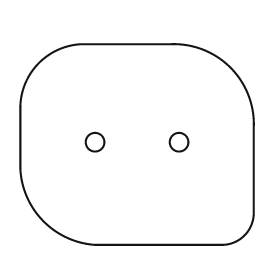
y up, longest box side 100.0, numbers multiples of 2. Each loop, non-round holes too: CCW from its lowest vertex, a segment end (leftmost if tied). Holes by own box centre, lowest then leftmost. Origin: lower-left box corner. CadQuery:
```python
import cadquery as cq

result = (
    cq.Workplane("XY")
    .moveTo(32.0, 0.0)
    .lineTo(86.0, 0.0)
    .threePointArc((96.0, 4.0), (100.0, 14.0))
    .lineTo(100.0, 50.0)
    .threePointArc((90.0, 76.0), (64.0, 86.0))
    .lineTo(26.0, 86.0)
    .threePointArc((8.0, 78.0), (0.0, 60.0))
    .lineTo(0.0, 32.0)
    .threePointArc((10.0, 10.0), (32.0, 0.0))
    .close()
    .moveTo(32.0, 44.0)
    .circle(4.0)
    .moveTo(68.0, 44.0)
    .circle(4.0)
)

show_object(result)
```